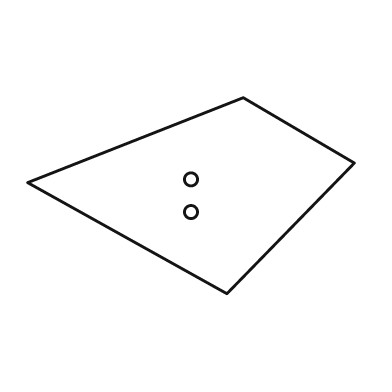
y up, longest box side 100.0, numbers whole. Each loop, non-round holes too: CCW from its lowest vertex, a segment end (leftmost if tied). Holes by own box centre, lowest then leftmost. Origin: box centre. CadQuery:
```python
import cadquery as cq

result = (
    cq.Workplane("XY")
    .moveTo(11.0, -30.0)
    .lineTo(50.0, 10.0)
    .lineTo(16.0, 30.0)
    .lineTo(-50.0, 4.0)
    .close()
    .moveTo(0.0, -5.0)
    .circle(2.0)
    .moveTo(0.0, 5.0)
    .circle(2.0)
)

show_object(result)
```